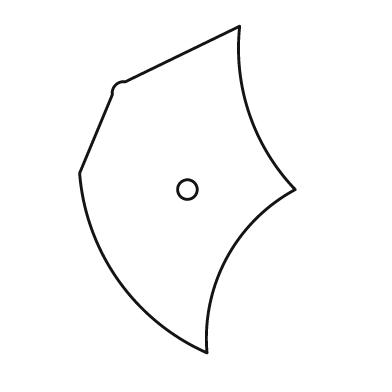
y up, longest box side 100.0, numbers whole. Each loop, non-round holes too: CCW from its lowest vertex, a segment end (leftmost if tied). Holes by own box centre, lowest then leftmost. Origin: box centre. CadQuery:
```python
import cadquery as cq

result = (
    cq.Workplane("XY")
    .moveTo(6.0, -50.0)
    .threePointArc((12.0, -21.0), (33.0, 0.0))
    .threePointArc((19.0, 23.0), (16.0, 50.0))
    .lineTo(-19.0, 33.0)
    .threePointArc((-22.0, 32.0), (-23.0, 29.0))
    .lineTo(-33.0, 5.0)
    .threePointArc((-21.0, -28.0), (6.0, -50.0))
    .close()
    .moveTo(0.0, 0.0)
    .circle(3.0)
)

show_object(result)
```